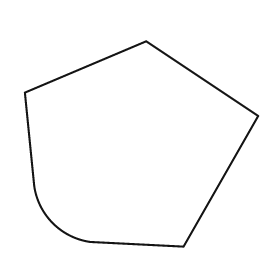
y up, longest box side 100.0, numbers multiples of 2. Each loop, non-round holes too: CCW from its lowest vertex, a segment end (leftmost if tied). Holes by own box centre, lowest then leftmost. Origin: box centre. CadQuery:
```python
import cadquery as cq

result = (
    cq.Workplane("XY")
    .moveTo(18.0, -44.0)
    .lineTo(50.0, 12.0)
    .lineTo(2.0, 44.0)
    .lineTo(-50.0, 22.0)
    .lineTo(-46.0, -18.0)
    .threePointArc((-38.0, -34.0), (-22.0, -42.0))
    .close()
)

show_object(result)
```